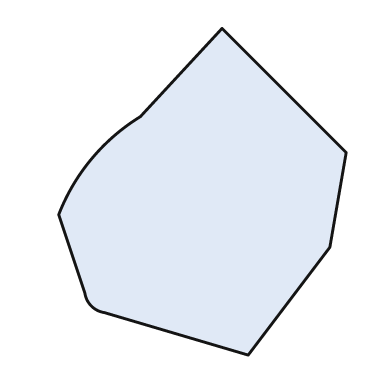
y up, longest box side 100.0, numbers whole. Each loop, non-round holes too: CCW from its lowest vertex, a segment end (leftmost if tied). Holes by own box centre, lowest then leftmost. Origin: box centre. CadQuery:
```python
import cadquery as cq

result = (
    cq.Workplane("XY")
    .moveTo(14.0, -50.0)
    .lineTo(39.0, -17.0)
    .lineTo(44.0, 12.0)
    .lineTo(6.0, 50.0)
    .lineTo(-19.0, 23.0)
    .threePointArc((-34.0, 10.0), (-44.0, -7.0))
    .lineTo(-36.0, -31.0)
    .threePointArc((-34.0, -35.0), (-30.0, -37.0))
    .close()
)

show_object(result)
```